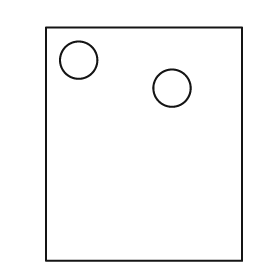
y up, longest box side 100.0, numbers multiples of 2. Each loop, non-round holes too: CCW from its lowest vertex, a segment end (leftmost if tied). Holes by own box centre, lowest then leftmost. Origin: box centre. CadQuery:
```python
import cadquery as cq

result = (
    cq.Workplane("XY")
    .moveTo(-42.0, -50.0)
    .lineTo(42.0, -50.0)
    .lineTo(42.0, 50.0)
    .lineTo(-42.0, 50.0)
    .close()
    .moveTo(12.0, 24.0)
    .circle(8.0)
    .moveTo(-28.0, 36.0)
    .circle(8.0)
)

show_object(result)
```